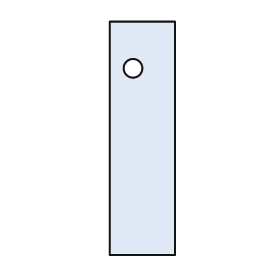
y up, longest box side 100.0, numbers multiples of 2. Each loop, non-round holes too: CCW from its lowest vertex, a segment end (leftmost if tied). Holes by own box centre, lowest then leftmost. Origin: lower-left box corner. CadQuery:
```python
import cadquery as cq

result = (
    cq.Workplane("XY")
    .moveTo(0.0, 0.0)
    .lineTo(28.0, 0.0)
    .lineTo(28.0, 100.0)
    .lineTo(0.0, 100.0)
    .close()
    .moveTo(10.0, 80.0)
    .circle(4.0)
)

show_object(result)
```